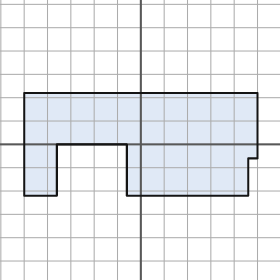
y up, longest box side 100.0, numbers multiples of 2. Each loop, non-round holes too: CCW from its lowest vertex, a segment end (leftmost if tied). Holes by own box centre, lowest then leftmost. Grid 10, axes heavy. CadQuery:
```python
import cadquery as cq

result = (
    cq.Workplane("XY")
    .moveTo(-50.0, -22.0)
    .lineTo(-36.0, -22.0)
    .lineTo(-36.0, 0.0)
    .lineTo(-6.0, 0.0)
    .lineTo(-6.0, -22.0)
    .lineTo(46.0, -22.0)
    .lineTo(46.0, -6.0)
    .lineTo(50.0, -6.0)
    .lineTo(50.0, 22.0)
    .lineTo(-50.0, 22.0)
    .close()
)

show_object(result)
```